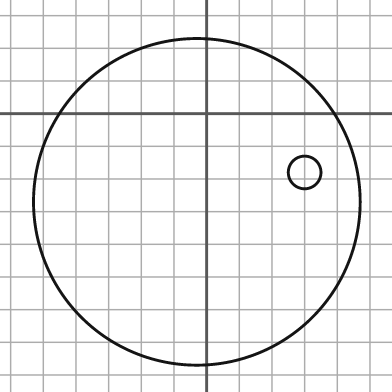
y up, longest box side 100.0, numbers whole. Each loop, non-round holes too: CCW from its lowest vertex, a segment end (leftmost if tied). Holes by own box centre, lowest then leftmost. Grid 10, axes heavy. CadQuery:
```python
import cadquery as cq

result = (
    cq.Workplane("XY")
    .moveTo(-3.0, -27.0)
    .circle(50.0)
    .moveTo(30.0, -18.0)
    .circle(5.0)
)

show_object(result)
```